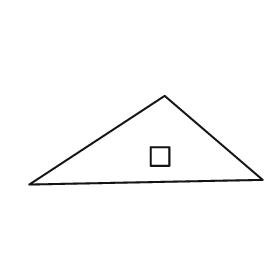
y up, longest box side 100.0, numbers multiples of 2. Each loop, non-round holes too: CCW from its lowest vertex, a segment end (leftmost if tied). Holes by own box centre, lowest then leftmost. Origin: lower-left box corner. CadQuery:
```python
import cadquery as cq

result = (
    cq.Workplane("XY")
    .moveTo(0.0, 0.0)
    .lineTo(100.0, 2.0)
    .lineTo(58.0, 38.0)
    .close()
    .moveTo(52.0, 8.0)
    .lineTo(60.0, 8.0)
    .lineTo(60.0, 16.0)
    .lineTo(52.0, 16.0)
    .close()
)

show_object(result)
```